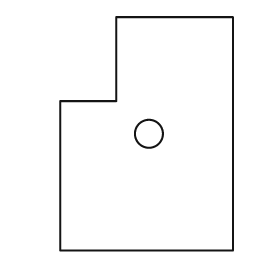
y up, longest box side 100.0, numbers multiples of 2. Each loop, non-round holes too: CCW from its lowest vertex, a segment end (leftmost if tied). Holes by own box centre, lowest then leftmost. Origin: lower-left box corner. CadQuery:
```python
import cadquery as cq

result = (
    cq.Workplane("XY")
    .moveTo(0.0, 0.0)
    .lineTo(74.0, 0.0)
    .lineTo(74.0, 100.0)
    .lineTo(24.0, 100.0)
    .lineTo(24.0, 64.0)
    .lineTo(0.0, 64.0)
    .close()
    .moveTo(38.0, 50.0)
    .circle(6.0)
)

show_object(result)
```